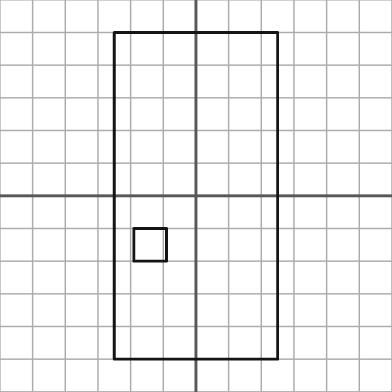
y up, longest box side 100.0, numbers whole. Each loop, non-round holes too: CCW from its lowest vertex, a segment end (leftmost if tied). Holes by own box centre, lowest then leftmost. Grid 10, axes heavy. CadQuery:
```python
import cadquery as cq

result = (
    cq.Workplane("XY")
    .moveTo(-25.0, -50.0)
    .lineTo(25.0, -50.0)
    .lineTo(25.0, 50.0)
    .lineTo(-25.0, 50.0)
    .close()
    .moveTo(-19.0, -20.0)
    .lineTo(-9.0, -20.0)
    .lineTo(-9.0, -10.0)
    .lineTo(-19.0, -10.0)
    .close()
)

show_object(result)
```